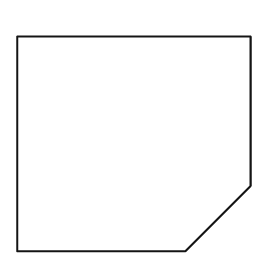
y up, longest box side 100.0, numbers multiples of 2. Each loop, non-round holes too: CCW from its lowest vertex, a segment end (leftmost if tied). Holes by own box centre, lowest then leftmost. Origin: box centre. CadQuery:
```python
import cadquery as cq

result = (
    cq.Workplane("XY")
    .moveTo(-50.0, -46.0)
    .lineTo(22.0, -46.0)
    .lineTo(50.0, -18.0)
    .lineTo(50.0, 46.0)
    .lineTo(-50.0, 46.0)
    .close()
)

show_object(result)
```